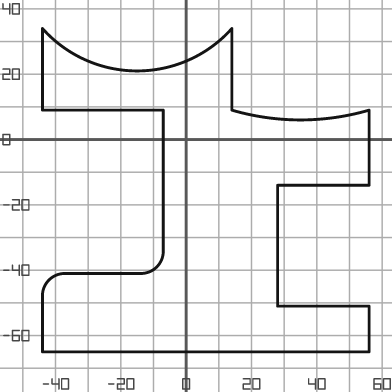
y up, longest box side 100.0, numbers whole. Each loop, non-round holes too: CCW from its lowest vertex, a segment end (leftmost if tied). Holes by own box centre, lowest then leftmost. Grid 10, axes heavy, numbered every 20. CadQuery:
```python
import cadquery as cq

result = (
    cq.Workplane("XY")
    .moveTo(-44.0, -65.0)
    .lineTo(56.0, -65.0)
    .lineTo(56.0, -51.0)
    .lineTo(28.0, -51.0)
    .lineTo(28.0, -14.0)
    .lineTo(56.0, -14.0)
    .lineTo(56.0, 9.0)
    .threePointArc((35.0, 6.0), (14.0, 9.0))
    .lineTo(14.0, 34.0)
    .threePointArc((-15.0, 21.0), (-44.0, 34.0))
    .lineTo(-44.0, 9.0)
    .lineTo(-7.0, 9.0)
    .lineTo(-7.0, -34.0)
    .threePointArc((-9.0, -39.0), (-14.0, -41.0))
    .lineTo(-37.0, -41.0)
    .threePointArc((-42.0, -43.0), (-44.0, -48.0))
    .close()
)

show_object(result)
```